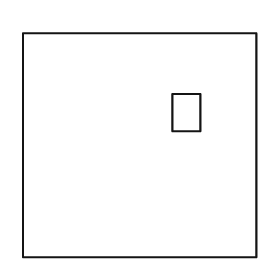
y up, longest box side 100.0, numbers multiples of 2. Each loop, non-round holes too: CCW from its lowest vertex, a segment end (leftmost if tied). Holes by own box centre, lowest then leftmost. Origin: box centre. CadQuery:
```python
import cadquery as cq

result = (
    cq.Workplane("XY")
    .moveTo(-50.0, -48.0)
    .lineTo(50.0, -48.0)
    .lineTo(50.0, 48.0)
    .lineTo(-50.0, 48.0)
    .close()
    .moveTo(14.0, 6.0)
    .lineTo(26.0, 6.0)
    .lineTo(26.0, 22.0)
    .lineTo(14.0, 22.0)
    .close()
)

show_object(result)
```